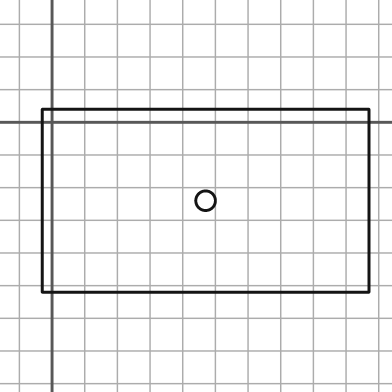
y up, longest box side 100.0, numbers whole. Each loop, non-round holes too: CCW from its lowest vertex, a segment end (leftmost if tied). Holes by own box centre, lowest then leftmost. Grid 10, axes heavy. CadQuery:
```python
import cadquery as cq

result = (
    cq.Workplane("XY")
    .moveTo(-3.0, -52.0)
    .lineTo(97.0, -52.0)
    .lineTo(97.0, 4.0)
    .lineTo(-3.0, 4.0)
    .close()
    .moveTo(47.0, -24.0)
    .circle(3.0)
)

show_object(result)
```